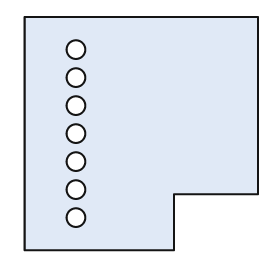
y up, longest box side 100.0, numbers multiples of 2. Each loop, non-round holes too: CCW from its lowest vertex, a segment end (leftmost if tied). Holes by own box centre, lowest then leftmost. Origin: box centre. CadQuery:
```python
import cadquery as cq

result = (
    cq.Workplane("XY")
    .moveTo(-50.0, -50.0)
    .lineTo(14.0, -50.0)
    .lineTo(14.0, -26.0)
    .lineTo(50.0, -26.0)
    .lineTo(50.0, 50.0)
    .lineTo(-50.0, 50.0)
    .close()
    .moveTo(-28.0, -36.0)
    .circle(4.0)
    .moveTo(-28.0, -24.0)
    .circle(4.0)
    .moveTo(-28.0, -12.0)
    .circle(4.0)
    .moveTo(-28.0, 0.0)
    .circle(4.0)
    .moveTo(-28.0, 12.0)
    .circle(4.0)
    .moveTo(-28.0, 24.0)
    .circle(4.0)
    .moveTo(-28.0, 36.0)
    .circle(4.0)
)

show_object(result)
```